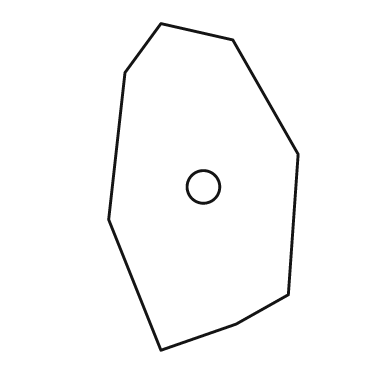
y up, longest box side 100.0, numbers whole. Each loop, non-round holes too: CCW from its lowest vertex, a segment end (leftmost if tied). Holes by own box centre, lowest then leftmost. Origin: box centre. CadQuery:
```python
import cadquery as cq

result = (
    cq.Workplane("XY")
    .moveTo(-13.0, -50.0)
    .lineTo(10.0, -42.0)
    .lineTo(26.0, -33.0)
    .lineTo(29.0, 10.0)
    .lineTo(9.0, 45.0)
    .lineTo(-13.0, 50.0)
    .lineTo(-24.0, 35.0)
    .lineTo(-29.0, -10.0)
    .close()
    .moveTo(0.0, 0.0)
    .circle(5.0)
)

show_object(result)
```